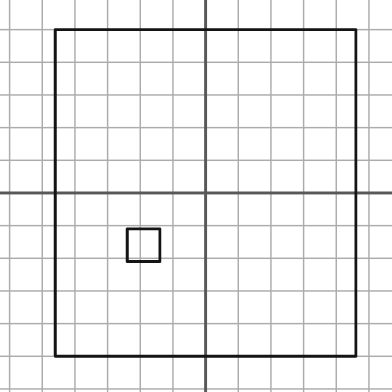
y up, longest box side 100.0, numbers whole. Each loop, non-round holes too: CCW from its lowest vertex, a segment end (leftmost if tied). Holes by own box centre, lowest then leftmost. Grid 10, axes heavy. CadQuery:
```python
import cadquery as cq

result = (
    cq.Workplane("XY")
    .moveTo(-46.0, -50.0)
    .lineTo(46.0, -50.0)
    .lineTo(46.0, 50.0)
    .lineTo(-46.0, 50.0)
    .close()
    .moveTo(-24.0, -21.0)
    .lineTo(-14.0, -21.0)
    .lineTo(-14.0, -11.0)
    .lineTo(-24.0, -11.0)
    .close()
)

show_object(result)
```